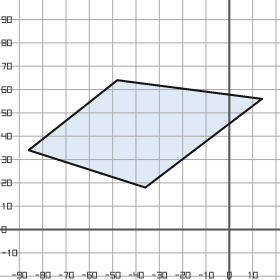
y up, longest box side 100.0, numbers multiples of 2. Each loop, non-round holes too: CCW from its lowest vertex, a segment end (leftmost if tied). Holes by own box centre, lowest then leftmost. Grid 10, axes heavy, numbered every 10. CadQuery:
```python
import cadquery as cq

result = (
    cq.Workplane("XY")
    .moveTo(-36.0, 18.0)
    .lineTo(14.0, 56.0)
    .lineTo(-48.0, 64.0)
    .lineTo(-86.0, 34.0)
    .close()
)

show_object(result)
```